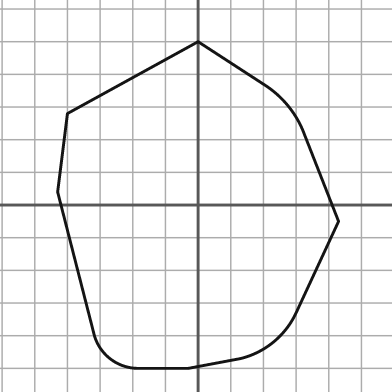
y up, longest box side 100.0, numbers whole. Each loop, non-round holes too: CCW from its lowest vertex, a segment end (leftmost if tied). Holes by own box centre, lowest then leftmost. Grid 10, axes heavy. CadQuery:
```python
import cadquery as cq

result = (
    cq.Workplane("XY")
    .moveTo(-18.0, -50.0)
    .lineTo(-3.0, -50.0)
    .lineTo(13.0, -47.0)
    .threePointArc((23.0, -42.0), (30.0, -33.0))
    .lineTo(43.0, -5.0)
    .lineTo(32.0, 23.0)
    .threePointArc((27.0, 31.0), (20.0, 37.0))
    .lineTo(0.0, 50.0)
    .lineTo(-40.0, 28.0)
    .lineTo(-43.0, 4.0)
    .lineTo(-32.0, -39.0)
    .threePointArc((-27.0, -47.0), (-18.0, -50.0))
    .close()
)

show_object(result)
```